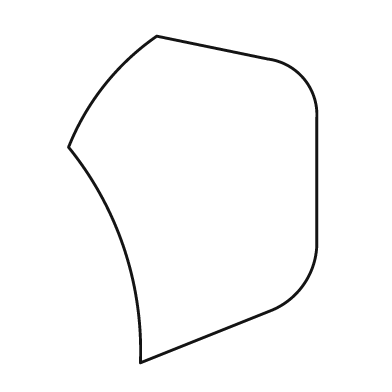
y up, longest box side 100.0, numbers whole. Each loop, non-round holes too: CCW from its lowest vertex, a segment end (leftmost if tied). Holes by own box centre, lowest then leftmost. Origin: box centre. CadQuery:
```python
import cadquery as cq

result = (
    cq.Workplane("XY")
    .moveTo(-16.0, -50.0)
    .lineTo(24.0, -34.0)
    .threePointArc((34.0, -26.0), (38.0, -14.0))
    .lineTo(38.0, 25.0)
    .threePointArc((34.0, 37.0), (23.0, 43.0))
    .lineTo(-11.0, 50.0)
    .threePointArc((-27.0, 35.0), (-38.0, 16.0))
    .threePointArc((-21.0, -15.0), (-16.0, -50.0))
    .close()
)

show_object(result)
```